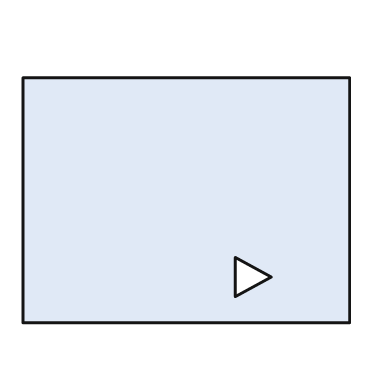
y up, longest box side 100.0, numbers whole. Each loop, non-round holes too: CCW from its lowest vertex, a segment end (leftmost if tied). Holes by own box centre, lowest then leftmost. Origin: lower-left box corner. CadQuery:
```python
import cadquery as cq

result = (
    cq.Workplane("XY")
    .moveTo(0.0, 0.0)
    .lineTo(100.0, 0.0)
    .lineTo(100.0, 75.0)
    .lineTo(0.0, 75.0)
    .close()
    .moveTo(65.0, 8.0)
    .lineTo(76.0, 14.0)
    .lineTo(65.0, 20.0)
    .close()
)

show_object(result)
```